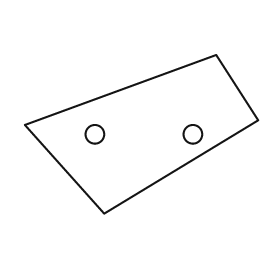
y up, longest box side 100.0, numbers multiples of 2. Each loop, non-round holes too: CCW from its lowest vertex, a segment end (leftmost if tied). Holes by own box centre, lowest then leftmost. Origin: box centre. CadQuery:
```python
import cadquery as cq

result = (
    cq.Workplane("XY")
    .moveTo(-16.0, -34.0)
    .lineTo(50.0, 6.0)
    .lineTo(32.0, 34.0)
    .lineTo(-50.0, 4.0)
    .close()
    .moveTo(-20.0, 0.0)
    .circle(4.0)
    .moveTo(22.0, 0.0)
    .circle(4.0)
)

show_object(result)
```